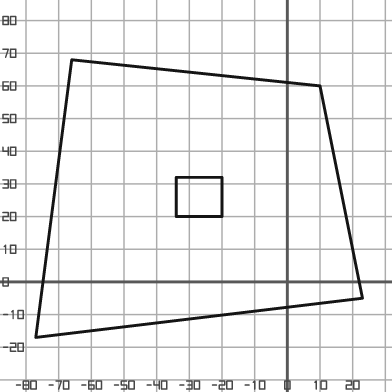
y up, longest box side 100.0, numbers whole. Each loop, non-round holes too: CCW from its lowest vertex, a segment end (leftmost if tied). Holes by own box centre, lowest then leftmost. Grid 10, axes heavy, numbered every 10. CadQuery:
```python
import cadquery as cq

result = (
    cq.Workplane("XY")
    .moveTo(-77.0, -17.0)
    .lineTo(23.0, -5.0)
    .lineTo(10.0, 60.0)
    .lineTo(-66.0, 68.0)
    .close()
    .moveTo(-34.0, 20.0)
    .lineTo(-20.0, 20.0)
    .lineTo(-20.0, 32.0)
    .lineTo(-34.0, 32.0)
    .close()
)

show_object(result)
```